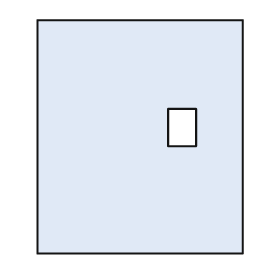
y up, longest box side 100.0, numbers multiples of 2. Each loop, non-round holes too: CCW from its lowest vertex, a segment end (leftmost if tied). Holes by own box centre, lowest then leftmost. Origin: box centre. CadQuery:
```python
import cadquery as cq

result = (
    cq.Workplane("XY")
    .moveTo(-44.0, -50.0)
    .lineTo(44.0, -50.0)
    .lineTo(44.0, 50.0)
    .lineTo(-44.0, 50.0)
    .close()
    .moveTo(12.0, -4.0)
    .lineTo(24.0, -4.0)
    .lineTo(24.0, 12.0)
    .lineTo(12.0, 12.0)
    .close()
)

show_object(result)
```